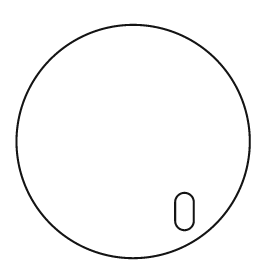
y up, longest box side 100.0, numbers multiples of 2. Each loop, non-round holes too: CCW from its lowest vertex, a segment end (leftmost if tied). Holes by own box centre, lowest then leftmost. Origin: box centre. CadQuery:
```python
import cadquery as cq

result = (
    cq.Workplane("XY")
    .moveTo(0.0, 0.0)
    .circle(50.0)
    .moveTo(18.0, -34.0)
    .threePointArc((22.0, -38.0), (26.0, -34.0))
    .lineTo(26.0, -26.0)
    .threePointArc((22.0, -22.0), (18.0, -26.0))
    .close()
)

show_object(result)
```